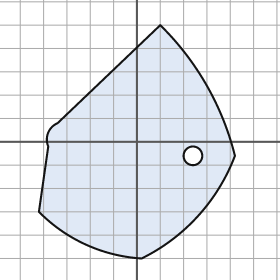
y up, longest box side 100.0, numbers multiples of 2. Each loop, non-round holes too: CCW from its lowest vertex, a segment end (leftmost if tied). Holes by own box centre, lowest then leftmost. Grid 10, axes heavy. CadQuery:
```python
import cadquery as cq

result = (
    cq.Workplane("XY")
    .moveTo(2.0, -50.0)
    .threePointArc((26.0, -32.0), (42.0, -6.0))
    .threePointArc((30.0, 24.0), (10.0, 50.0))
    .lineTo(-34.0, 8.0)
    .threePointArc((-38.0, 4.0), (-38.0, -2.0))
    .lineTo(-42.0, -30.0)
    .threePointArc((-22.0, -44.0), (2.0, -50.0))
    .close()
    .moveTo(24.0, -6.0)
    .circle(4.0)
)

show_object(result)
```